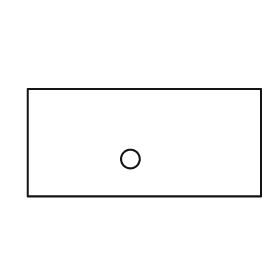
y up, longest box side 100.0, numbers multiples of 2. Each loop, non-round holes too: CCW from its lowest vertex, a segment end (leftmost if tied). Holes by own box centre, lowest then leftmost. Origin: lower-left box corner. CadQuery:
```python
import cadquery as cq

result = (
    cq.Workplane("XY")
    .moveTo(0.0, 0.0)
    .lineTo(100.0, 0.0)
    .lineTo(100.0, 46.0)
    .lineTo(0.0, 46.0)
    .close()
    .moveTo(44.0, 16.0)
    .circle(4.0)
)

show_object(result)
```